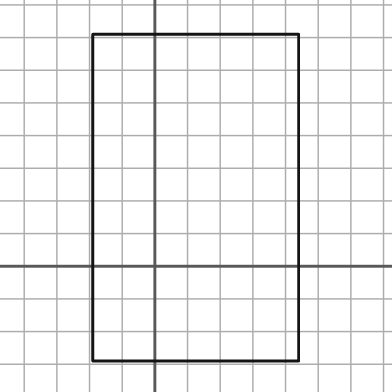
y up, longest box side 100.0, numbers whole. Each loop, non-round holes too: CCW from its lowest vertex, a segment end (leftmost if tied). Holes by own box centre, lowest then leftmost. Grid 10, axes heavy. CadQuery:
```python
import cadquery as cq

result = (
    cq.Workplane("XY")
    .moveTo(-19.0, -29.0)
    .lineTo(44.0, -29.0)
    .lineTo(44.0, 71.0)
    .lineTo(-19.0, 71.0)
    .close()
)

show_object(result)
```